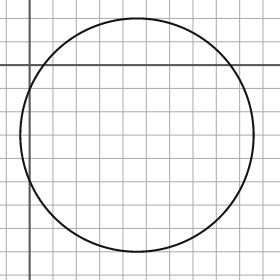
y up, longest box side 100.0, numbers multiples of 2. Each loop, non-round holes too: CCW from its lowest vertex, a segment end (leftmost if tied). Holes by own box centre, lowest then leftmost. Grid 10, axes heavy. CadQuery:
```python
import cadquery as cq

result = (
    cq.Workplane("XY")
    .moveTo(46.0, -30.0)
    .circle(50.0)
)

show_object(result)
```